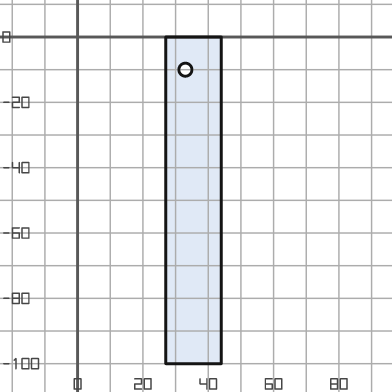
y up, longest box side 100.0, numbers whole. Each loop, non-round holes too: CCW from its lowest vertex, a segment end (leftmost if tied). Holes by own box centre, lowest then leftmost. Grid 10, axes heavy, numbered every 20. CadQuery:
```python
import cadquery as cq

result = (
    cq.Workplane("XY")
    .moveTo(27.0, -100.0)
    .lineTo(44.0, -100.0)
    .lineTo(44.0, 0.0)
    .lineTo(27.0, 0.0)
    .close()
    .moveTo(33.0, -10.0)
    .circle(2.0)
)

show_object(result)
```